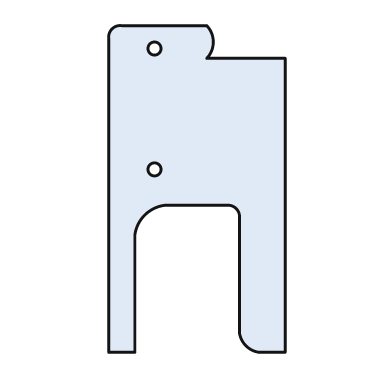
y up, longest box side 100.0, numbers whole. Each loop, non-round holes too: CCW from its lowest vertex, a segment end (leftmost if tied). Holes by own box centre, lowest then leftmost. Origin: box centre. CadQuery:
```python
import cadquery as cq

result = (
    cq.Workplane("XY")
    .moveTo(-27.0, -50.0)
    .lineTo(-19.0, -50.0)
    .lineTo(-19.0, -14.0)
    .threePointArc((-16.0, -8.0), (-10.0, -5.0))
    .lineTo(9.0, -5.0)
    .threePointArc((12.0, -6.0), (13.0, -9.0))
    .lineTo(13.0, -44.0)
    .threePointArc((15.0, -48.0), (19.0, -50.0))
    .lineTo(27.0, -50.0)
    .lineTo(27.0, 40.0)
    .lineTo(3.0, 40.0)
    .threePointArc((5.0, 45.0), (3.0, 50.0))
    .lineTo(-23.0, 50.0)
    .threePointArc((-26.0, 49.0), (-27.0, 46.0))
    .close()
    .moveTo(-13.0, 6.0)
    .circle(2.0)
    .moveTo(-13.0, 43.0)
    .circle(2.0)
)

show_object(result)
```